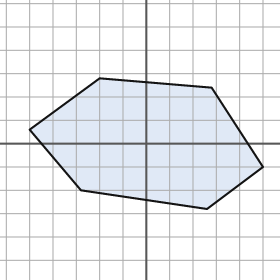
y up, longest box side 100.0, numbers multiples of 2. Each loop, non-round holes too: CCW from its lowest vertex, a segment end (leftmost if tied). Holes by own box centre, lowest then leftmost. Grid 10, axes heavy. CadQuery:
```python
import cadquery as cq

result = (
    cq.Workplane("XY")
    .moveTo(26.0, -28.0)
    .lineTo(50.0, -10.0)
    .lineTo(28.0, 24.0)
    .lineTo(-20.0, 28.0)
    .lineTo(-50.0, 6.0)
    .lineTo(-28.0, -20.0)
    .close()
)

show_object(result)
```